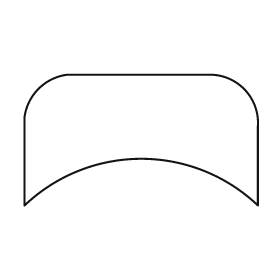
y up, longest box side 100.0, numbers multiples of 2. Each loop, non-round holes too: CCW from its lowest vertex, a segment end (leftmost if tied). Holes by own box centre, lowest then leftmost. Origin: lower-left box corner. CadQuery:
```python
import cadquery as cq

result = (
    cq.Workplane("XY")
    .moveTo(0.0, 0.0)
    .threePointArc((50.0, 20.0), (100.0, 0.0))
    .lineTo(100.0, 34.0)
    .threePointArc((94.0, 50.0), (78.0, 56.0))
    .lineTo(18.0, 56.0)
    .threePointArc((6.0, 50.0), (0.0, 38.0))
    .close()
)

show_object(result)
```